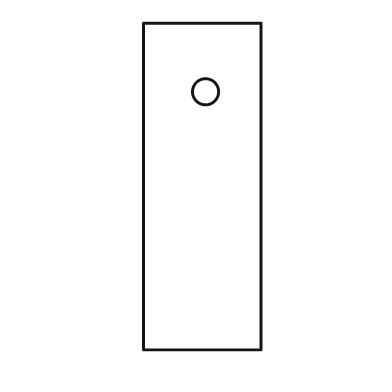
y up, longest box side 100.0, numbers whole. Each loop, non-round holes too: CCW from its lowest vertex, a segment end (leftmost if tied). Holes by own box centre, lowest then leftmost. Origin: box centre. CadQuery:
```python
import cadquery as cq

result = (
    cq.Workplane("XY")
    .moveTo(-18.0, -50.0)
    .lineTo(18.0, -50.0)
    .lineTo(18.0, 50.0)
    .lineTo(-18.0, 50.0)
    .close()
    .moveTo(1.0, 29.0)
    .circle(4.0)
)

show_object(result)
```